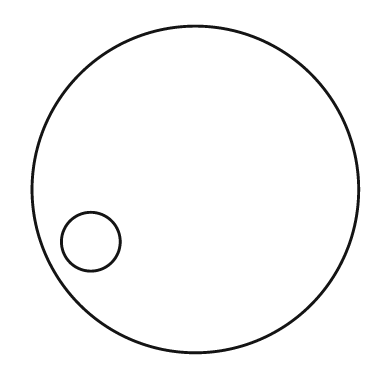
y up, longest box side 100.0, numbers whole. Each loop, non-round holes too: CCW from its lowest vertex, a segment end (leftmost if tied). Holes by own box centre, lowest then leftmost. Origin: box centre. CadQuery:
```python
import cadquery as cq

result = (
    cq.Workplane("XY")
    .moveTo(0.0, 0.0)
    .circle(50.0)
    .moveTo(-32.0, -16.0)
    .circle(9.0)
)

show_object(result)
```